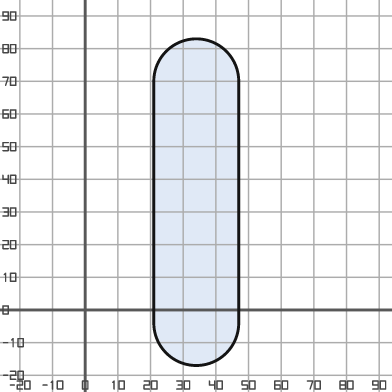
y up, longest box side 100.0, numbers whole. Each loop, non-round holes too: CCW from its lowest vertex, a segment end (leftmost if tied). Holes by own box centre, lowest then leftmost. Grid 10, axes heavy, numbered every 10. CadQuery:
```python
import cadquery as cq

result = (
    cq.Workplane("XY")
    .moveTo(21.0, -4.0)
    .threePointArc((34.0, -17.0), (47.0, -4.0))
    .lineTo(47.0, 70.0)
    .threePointArc((34.0, 83.0), (21.0, 70.0))
    .close()
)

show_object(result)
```